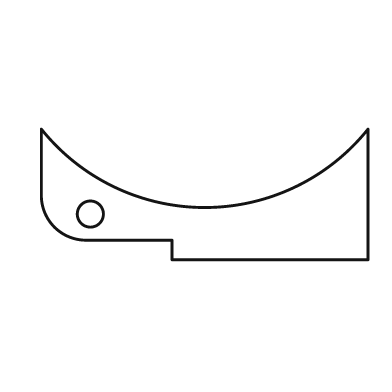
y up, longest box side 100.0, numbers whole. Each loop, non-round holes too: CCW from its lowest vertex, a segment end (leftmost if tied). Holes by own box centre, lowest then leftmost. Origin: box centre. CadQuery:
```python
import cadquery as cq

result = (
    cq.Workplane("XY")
    .moveTo(-10.0, -20.0)
    .lineTo(50.0, -20.0)
    .lineTo(50.0, 20.0)
    .threePointArc((0.0, -4.0), (-50.0, 20.0))
    .lineTo(-50.0, 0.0)
    .threePointArc((-46.0, -10.0), (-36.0, -14.0))
    .lineTo(-10.0, -14.0)
    .close()
    .moveTo(-35.0, -6.0)
    .circle(4.0)
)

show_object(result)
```